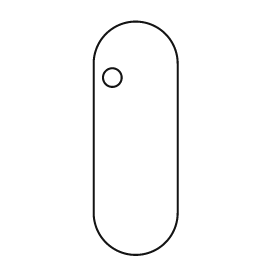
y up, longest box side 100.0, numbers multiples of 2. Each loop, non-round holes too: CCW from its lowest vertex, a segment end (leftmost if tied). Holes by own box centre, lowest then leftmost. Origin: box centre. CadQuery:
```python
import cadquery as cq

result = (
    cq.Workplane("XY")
    .moveTo(-18.0, -32.0)
    .threePointArc((0.0, -50.0), (18.0, -32.0))
    .lineTo(18.0, 32.0)
    .threePointArc((0.0, 50.0), (-18.0, 32.0))
    .close()
    .moveTo(-10.0, 26.0)
    .circle(4.0)
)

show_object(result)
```